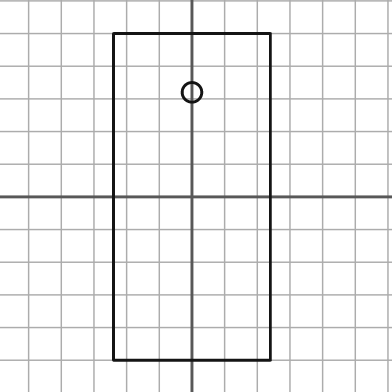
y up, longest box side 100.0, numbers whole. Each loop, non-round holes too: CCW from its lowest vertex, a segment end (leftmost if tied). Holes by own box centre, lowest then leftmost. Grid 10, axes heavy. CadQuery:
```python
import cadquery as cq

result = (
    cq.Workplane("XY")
    .moveTo(-24.0, -50.0)
    .lineTo(24.0, -50.0)
    .lineTo(24.0, 50.0)
    .lineTo(-24.0, 50.0)
    .close()
    .moveTo(0.0, 32.0)
    .circle(3.0)
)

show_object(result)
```